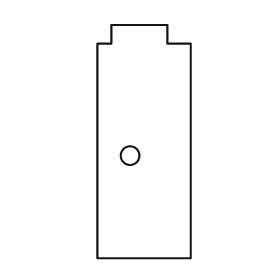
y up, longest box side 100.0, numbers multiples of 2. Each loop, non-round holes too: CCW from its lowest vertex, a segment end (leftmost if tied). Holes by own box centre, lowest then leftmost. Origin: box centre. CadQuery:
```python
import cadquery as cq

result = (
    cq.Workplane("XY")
    .moveTo(-20.0, -50.0)
    .lineTo(20.0, -50.0)
    .lineTo(20.0, 42.0)
    .lineTo(10.0, 42.0)
    .lineTo(10.0, 50.0)
    .lineTo(-14.0, 50.0)
    .lineTo(-14.0, 42.0)
    .lineTo(-20.0, 42.0)
    .close()
    .moveTo(-6.0, -6.0)
    .circle(4.0)
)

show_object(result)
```